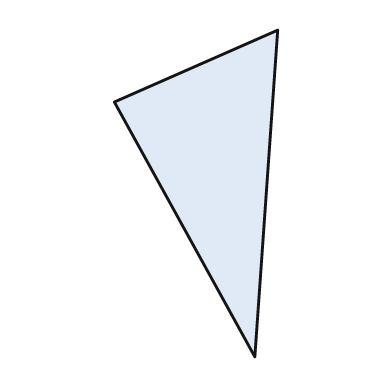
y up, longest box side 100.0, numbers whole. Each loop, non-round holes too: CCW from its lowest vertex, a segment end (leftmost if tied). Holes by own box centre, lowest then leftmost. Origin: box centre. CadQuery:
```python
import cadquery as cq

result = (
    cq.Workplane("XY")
    .moveTo(18.0, -50.0)
    .lineTo(25.0, 50.0)
    .lineTo(-25.0, 28.0)
    .close()
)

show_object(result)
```